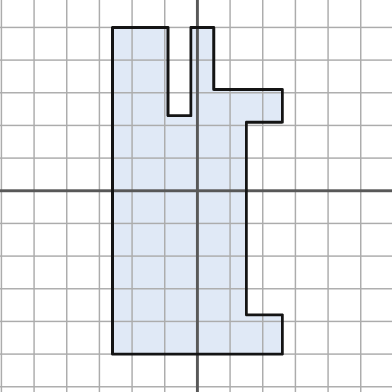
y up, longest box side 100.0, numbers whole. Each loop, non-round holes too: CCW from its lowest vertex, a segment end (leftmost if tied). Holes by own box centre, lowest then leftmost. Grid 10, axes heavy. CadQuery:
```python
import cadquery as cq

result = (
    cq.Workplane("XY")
    .moveTo(-26.0, -50.0)
    .lineTo(26.0, -50.0)
    .lineTo(26.0, -38.0)
    .lineTo(15.0, -38.0)
    .lineTo(15.0, 21.0)
    .lineTo(26.0, 21.0)
    .lineTo(26.0, 31.0)
    .lineTo(5.0, 31.0)
    .lineTo(5.0, 50.0)
    .lineTo(-2.0, 50.0)
    .lineTo(-2.0, 23.0)
    .lineTo(-9.0, 23.0)
    .lineTo(-9.0, 50.0)
    .lineTo(-26.0, 50.0)
    .close()
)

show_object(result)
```